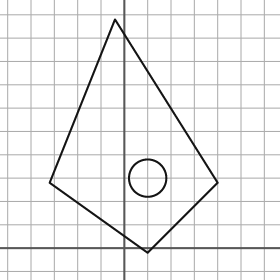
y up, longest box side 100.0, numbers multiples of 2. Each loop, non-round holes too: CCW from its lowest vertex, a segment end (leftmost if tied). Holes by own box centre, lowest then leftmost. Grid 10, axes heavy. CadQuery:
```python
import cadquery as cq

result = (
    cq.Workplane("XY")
    .moveTo(10.0, -2.0)
    .lineTo(40.0, 28.0)
    .lineTo(-4.0, 98.0)
    .lineTo(-32.0, 28.0)
    .close()
    .moveTo(10.0, 30.0)
    .circle(8.0)
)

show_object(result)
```